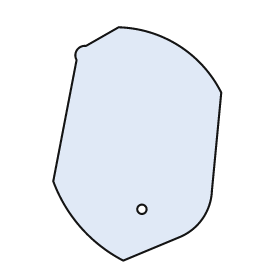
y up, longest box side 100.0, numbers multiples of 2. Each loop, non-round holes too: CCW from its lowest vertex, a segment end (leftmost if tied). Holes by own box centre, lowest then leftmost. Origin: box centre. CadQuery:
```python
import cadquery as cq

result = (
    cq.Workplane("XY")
    .moveTo(-6.0, -50.0)
    .lineTo(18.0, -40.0)
    .threePointArc((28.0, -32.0), (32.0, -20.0))
    .lineTo(36.0, 22.0)
    .threePointArc((18.0, 42.0), (-8.0, 50.0))
    .lineTo(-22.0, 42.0)
    .threePointArc((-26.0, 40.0), (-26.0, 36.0))
    .lineTo(-36.0, -16.0)
    .threePointArc((-24.0, -36.0), (-6.0, -50.0))
    .close()
    .moveTo(2.0, -28.0)
    .circle(2.0)
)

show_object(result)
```